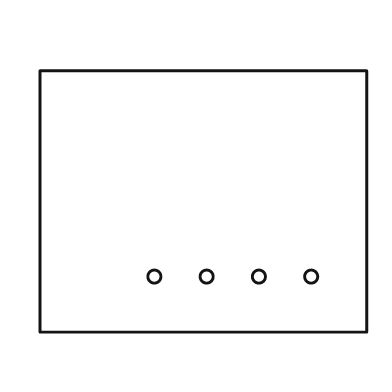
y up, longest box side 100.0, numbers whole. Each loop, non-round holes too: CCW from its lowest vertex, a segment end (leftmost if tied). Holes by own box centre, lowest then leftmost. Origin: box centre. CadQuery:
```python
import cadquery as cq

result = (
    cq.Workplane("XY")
    .moveTo(-50.0, -40.0)
    .lineTo(50.0, -40.0)
    .lineTo(50.0, 40.0)
    .lineTo(-50.0, 40.0)
    .close()
    .moveTo(-15.0, -23.0)
    .circle(2.0)
    .moveTo(1.0, -23.0)
    .circle(2.0)
    .moveTo(17.0, -23.0)
    .circle(2.0)
    .moveTo(33.0, -23.0)
    .circle(2.0)
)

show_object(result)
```